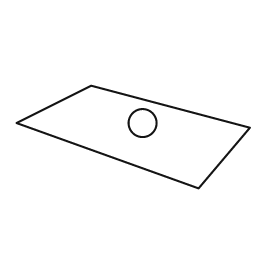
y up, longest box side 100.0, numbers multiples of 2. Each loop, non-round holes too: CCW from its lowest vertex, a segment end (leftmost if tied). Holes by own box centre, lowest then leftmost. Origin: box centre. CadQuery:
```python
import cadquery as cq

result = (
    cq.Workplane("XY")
    .moveTo(28.0, -22.0)
    .lineTo(50.0, 4.0)
    .lineTo(-18.0, 22.0)
    .lineTo(-50.0, 6.0)
    .close()
    .moveTo(4.0, 6.0)
    .circle(6.0)
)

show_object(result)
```